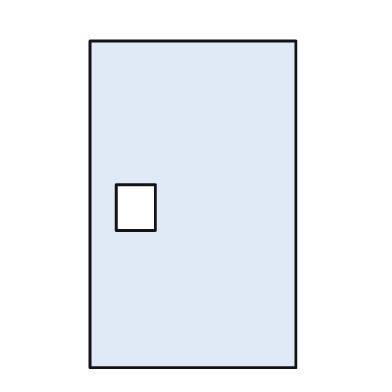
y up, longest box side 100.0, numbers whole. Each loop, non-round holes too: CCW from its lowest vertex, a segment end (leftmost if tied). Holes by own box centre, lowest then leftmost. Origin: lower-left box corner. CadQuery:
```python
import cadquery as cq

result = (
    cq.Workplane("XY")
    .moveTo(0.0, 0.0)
    .lineTo(63.0, 0.0)
    .lineTo(63.0, 100.0)
    .lineTo(0.0, 100.0)
    .close()
    .moveTo(8.0, 42.0)
    .lineTo(20.0, 42.0)
    .lineTo(20.0, 56.0)
    .lineTo(8.0, 56.0)
    .close()
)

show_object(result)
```